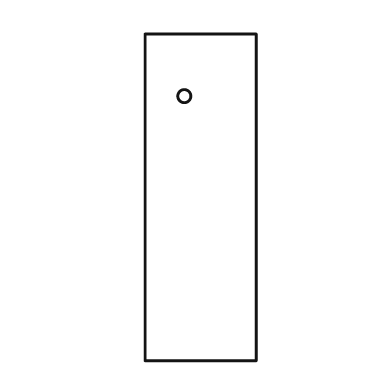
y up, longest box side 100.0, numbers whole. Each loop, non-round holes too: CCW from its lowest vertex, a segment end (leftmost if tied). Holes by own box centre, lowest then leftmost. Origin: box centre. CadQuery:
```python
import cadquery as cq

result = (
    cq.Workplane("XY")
    .moveTo(-17.0, -50.0)
    .lineTo(17.0, -50.0)
    .lineTo(17.0, 50.0)
    .lineTo(-17.0, 50.0)
    .close()
    .moveTo(-5.0, 31.0)
    .circle(2.0)
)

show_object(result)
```